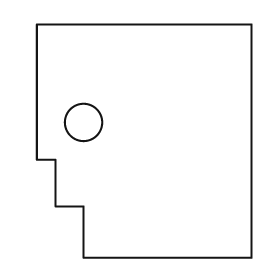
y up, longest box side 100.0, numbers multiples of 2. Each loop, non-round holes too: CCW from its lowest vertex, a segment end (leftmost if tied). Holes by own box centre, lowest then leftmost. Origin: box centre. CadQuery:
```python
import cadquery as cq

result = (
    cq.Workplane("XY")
    .moveTo(-26.0, -50.0)
    .lineTo(46.0, -50.0)
    .lineTo(46.0, 50.0)
    .lineTo(-46.0, 50.0)
    .lineTo(-46.0, -8.0)
    .lineTo(-38.0, -8.0)
    .lineTo(-38.0, -28.0)
    .lineTo(-26.0, -28.0)
    .close()
    .moveTo(-26.0, 8.0)
    .circle(8.0)
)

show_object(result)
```